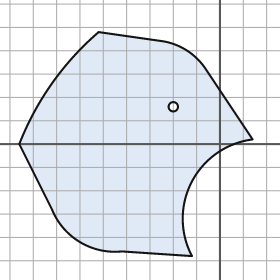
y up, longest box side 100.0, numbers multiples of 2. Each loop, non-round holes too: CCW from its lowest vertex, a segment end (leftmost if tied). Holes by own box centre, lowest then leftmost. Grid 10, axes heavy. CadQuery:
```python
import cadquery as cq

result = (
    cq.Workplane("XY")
    .moveTo(-12.0, -48.0)
    .threePointArc((-12.0, -16.0), (14.0, 2.0))
    .lineTo(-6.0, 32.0)
    .threePointArc((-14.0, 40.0), (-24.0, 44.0))
    .lineTo(-52.0, 48.0)
    .threePointArc((-72.0, 26.0), (-86.0, 0.0))
    .lineTo(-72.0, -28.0)
    .threePointArc((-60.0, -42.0), (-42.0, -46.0))
    .close()
    .moveTo(-20.0, 16.0)
    .circle(2.0)
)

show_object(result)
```